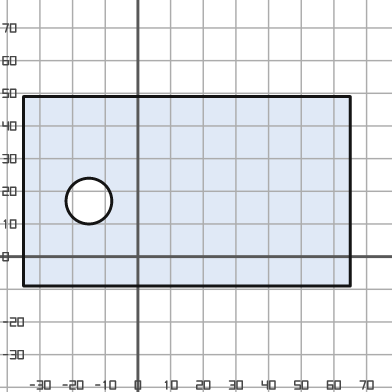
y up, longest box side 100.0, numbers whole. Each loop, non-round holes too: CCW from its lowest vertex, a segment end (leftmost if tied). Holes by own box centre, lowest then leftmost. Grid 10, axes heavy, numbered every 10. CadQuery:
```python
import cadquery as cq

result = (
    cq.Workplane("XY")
    .moveTo(-35.0, -9.0)
    .lineTo(65.0, -9.0)
    .lineTo(65.0, 49.0)
    .lineTo(-35.0, 49.0)
    .close()
    .moveTo(-15.0, 17.0)
    .circle(7.0)
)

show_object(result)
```